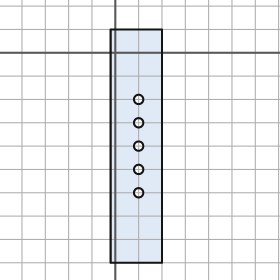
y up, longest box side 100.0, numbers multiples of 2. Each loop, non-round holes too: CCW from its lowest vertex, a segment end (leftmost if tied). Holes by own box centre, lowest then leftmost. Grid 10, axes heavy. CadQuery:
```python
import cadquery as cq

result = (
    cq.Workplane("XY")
    .moveTo(-2.0, -90.0)
    .lineTo(20.0, -90.0)
    .lineTo(20.0, 10.0)
    .lineTo(-2.0, 10.0)
    .close()
    .moveTo(10.0, -60.0)
    .circle(2.0)
    .moveTo(10.0, -50.0)
    .circle(2.0)
    .moveTo(10.0, -40.0)
    .circle(2.0)
    .moveTo(10.0, -30.0)
    .circle(2.0)
    .moveTo(10.0, -20.0)
    .circle(2.0)
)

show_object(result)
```